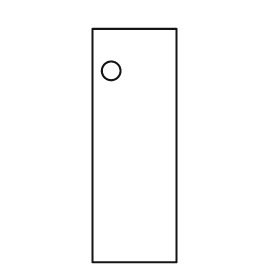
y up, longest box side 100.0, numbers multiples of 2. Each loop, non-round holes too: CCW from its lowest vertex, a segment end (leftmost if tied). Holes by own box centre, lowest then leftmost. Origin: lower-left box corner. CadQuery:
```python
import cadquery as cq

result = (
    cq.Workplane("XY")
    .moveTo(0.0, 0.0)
    .lineTo(36.0, 0.0)
    .lineTo(36.0, 100.0)
    .lineTo(0.0, 100.0)
    .close()
    .moveTo(8.0, 82.0)
    .circle(4.0)
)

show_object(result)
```